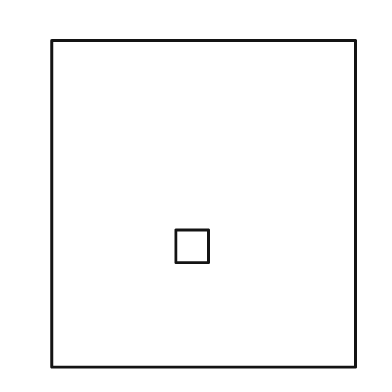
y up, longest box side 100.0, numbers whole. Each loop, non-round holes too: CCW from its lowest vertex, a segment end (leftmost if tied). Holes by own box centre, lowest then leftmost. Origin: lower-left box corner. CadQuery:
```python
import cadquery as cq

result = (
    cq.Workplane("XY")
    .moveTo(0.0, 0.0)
    .lineTo(93.0, 0.0)
    .lineTo(93.0, 100.0)
    .lineTo(0.0, 100.0)
    .close()
    .moveTo(38.0, 32.0)
    .lineTo(48.0, 32.0)
    .lineTo(48.0, 42.0)
    .lineTo(38.0, 42.0)
    .close()
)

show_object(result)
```